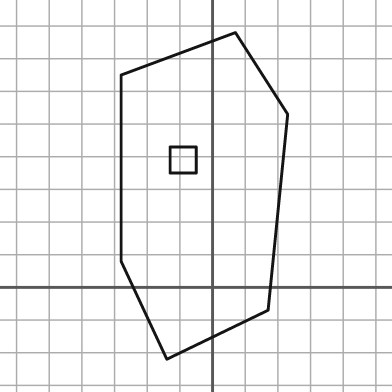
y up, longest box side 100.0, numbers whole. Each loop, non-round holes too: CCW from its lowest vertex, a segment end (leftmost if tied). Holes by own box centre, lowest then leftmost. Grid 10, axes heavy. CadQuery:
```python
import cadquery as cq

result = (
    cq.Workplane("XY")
    .moveTo(-14.0, -22.0)
    .lineTo(17.0, -7.0)
    .lineTo(23.0, 53.0)
    .lineTo(7.0, 78.0)
    .lineTo(-28.0, 65.0)
    .lineTo(-28.0, 8.0)
    .close()
    .moveTo(-13.0, 35.0)
    .lineTo(-5.0, 35.0)
    .lineTo(-5.0, 43.0)
    .lineTo(-13.0, 43.0)
    .close()
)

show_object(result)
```